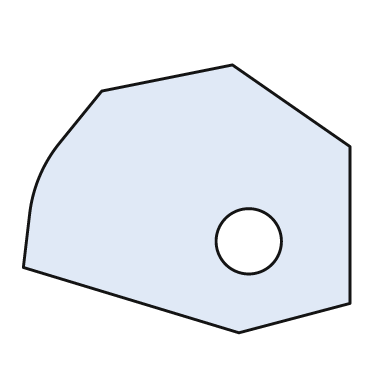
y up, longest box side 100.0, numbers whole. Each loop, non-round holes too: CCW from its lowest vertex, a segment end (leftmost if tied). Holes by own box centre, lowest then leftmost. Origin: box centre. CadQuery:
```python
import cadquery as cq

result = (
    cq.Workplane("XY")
    .moveTo(16.0, -41.0)
    .lineTo(50.0, -32.0)
    .lineTo(50.0, 16.0)
    .lineTo(14.0, 41.0)
    .lineTo(-26.0, 33.0)
    .lineTo(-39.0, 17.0)
    .threePointArc((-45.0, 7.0), (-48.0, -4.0))
    .lineTo(-50.0, -21.0)
    .close()
    .moveTo(19.0, -13.0)
    .circle(10.0)
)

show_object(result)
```